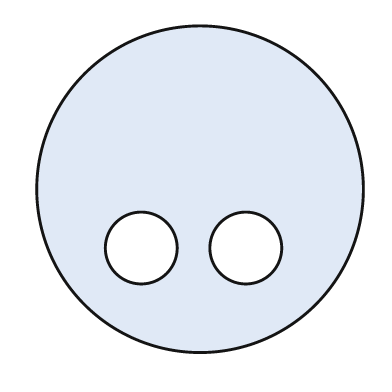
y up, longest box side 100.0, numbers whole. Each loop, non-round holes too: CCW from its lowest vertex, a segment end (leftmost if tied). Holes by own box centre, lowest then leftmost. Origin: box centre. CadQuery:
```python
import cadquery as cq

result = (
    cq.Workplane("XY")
    .moveTo(0.0, 0.0)
    .circle(50.0)
    .moveTo(-18.0, -18.0)
    .circle(11.0)
    .moveTo(14.0, -18.0)
    .circle(11.0)
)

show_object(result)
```